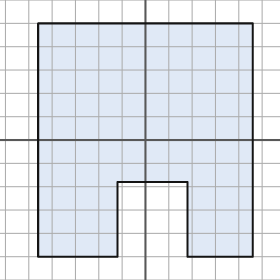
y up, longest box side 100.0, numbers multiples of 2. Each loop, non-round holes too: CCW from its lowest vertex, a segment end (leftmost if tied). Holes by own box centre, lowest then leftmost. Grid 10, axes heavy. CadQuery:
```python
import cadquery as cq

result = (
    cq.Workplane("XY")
    .moveTo(-46.0, -50.0)
    .lineTo(-12.0, -50.0)
    .lineTo(-12.0, -18.0)
    .lineTo(18.0, -18.0)
    .lineTo(18.0, -50.0)
    .lineTo(46.0, -50.0)
    .lineTo(46.0, 50.0)
    .lineTo(-46.0, 50.0)
    .close()
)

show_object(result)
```